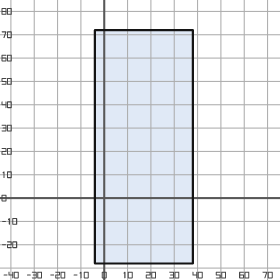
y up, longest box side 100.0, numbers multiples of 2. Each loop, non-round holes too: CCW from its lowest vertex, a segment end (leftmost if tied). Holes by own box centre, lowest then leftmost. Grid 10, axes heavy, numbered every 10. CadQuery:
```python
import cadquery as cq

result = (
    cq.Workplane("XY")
    .moveTo(-4.0, -28.0)
    .lineTo(38.0, -28.0)
    .lineTo(38.0, 72.0)
    .lineTo(-4.0, 72.0)
    .close()
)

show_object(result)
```